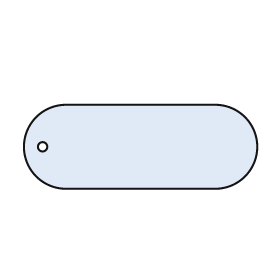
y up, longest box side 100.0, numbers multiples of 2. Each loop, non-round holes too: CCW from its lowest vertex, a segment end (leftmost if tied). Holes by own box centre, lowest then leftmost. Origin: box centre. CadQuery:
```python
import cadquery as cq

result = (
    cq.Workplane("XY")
    .moveTo(-32.0, -18.0)
    .lineTo(32.0, -18.0)
    .threePointArc((50.0, 0.0), (32.0, 18.0))
    .lineTo(-32.0, 18.0)
    .threePointArc((-50.0, 0.0), (-32.0, -18.0))
    .close()
    .moveTo(-42.0, 0.0)
    .circle(2.0)
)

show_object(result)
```